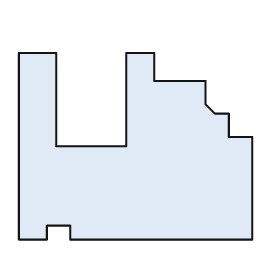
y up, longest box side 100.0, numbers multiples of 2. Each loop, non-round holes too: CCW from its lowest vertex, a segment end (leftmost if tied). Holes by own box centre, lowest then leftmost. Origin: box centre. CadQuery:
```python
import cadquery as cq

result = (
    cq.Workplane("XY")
    .moveTo(-50.0, -40.0)
    .lineTo(-38.0, -40.0)
    .lineTo(-38.0, -34.0)
    .lineTo(-28.0, -34.0)
    .lineTo(-28.0, -40.0)
    .lineTo(50.0, -40.0)
    .lineTo(50.0, 4.0)
    .lineTo(40.0, 4.0)
    .lineTo(40.0, 14.0)
    .lineTo(34.0, 14.0)
    .lineTo(30.0, 18.0)
    .lineTo(30.0, 28.0)
    .lineTo(8.0, 28.0)
    .lineTo(8.0, 40.0)
    .lineTo(-4.0, 40.0)
    .lineTo(-4.0, 0.0)
    .lineTo(-34.0, 0.0)
    .lineTo(-34.0, 40.0)
    .lineTo(-50.0, 40.0)
    .close()
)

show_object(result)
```